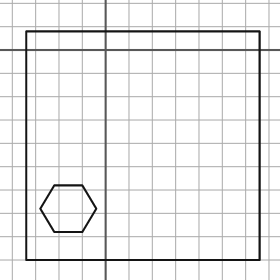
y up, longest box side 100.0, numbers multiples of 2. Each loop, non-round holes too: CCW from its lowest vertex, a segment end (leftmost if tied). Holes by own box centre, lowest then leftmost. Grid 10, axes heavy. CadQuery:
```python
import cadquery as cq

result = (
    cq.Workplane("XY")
    .moveTo(-34.0, -90.0)
    .lineTo(66.0, -90.0)
    .lineTo(66.0, 8.0)
    .lineTo(-34.0, 8.0)
    .close()
    .moveTo(-22.0, -78.0)
    .lineTo(-10.0, -78.0)
    .lineTo(-4.0, -68.0)
    .lineTo(-10.0, -58.0)
    .lineTo(-22.0, -58.0)
    .lineTo(-28.0, -68.0)
    .close()
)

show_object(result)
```